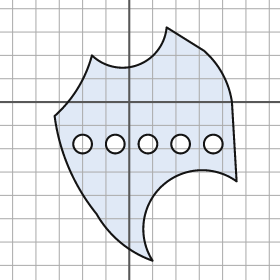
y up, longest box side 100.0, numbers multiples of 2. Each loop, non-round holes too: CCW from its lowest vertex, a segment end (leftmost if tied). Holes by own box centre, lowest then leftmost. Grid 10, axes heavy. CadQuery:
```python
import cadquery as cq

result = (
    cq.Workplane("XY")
    .moveTo(10.0, -68.0)
    .threePointArc((14.0, -36.0), (46.0, -34.0))
    .lineTo(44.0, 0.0)
    .threePointArc((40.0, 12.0), (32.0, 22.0))
    .lineTo(16.0, 32.0)
    .threePointArc((4.0, 16.0), (-16.0, 20.0))
    .threePointArc((-22.0, 6.0), (-32.0, -6.0))
    .threePointArc((-26.0, -28.0), (-14.0, -48.0))
    .threePointArc((-4.0, -60.0), (10.0, -68.0))
    .close()
    .moveTo(-20.0, -18.0)
    .circle(4.0)
    .moveTo(-6.0, -18.0)
    .circle(4.0)
    .moveTo(8.0, -18.0)
    .circle(4.0)
    .moveTo(22.0, -18.0)
    .circle(4.0)
    .moveTo(36.0, -18.0)
    .circle(4.0)
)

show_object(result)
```